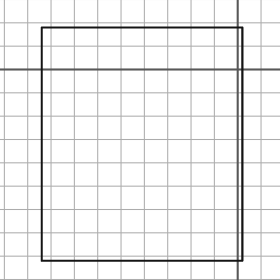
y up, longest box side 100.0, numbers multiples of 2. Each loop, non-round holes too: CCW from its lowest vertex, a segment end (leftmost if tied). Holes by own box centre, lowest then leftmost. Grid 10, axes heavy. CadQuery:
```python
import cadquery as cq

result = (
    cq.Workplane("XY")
    .moveTo(-84.0, -82.0)
    .lineTo(2.0, -82.0)
    .lineTo(2.0, 18.0)
    .lineTo(-84.0, 18.0)
    .close()
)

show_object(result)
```